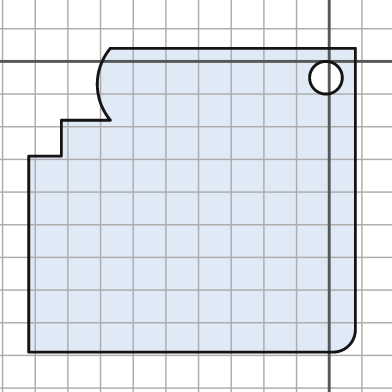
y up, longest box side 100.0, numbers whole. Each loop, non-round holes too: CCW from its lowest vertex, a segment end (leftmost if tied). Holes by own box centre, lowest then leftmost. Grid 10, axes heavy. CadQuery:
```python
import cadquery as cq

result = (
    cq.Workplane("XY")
    .moveTo(-92.0, -89.0)
    .lineTo(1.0, -89.0)
    .threePointArc((6.0, -87.0), (8.0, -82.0))
    .lineTo(8.0, 4.0)
    .lineTo(-67.0, 4.0)
    .threePointArc((-71.0, -7.0), (-67.0, -18.0))
    .lineTo(-82.0, -18.0)
    .lineTo(-82.0, -29.0)
    .lineTo(-92.0, -29.0)
    .close()
    .moveTo(-1.0, -5.0)
    .circle(5.0)
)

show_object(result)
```